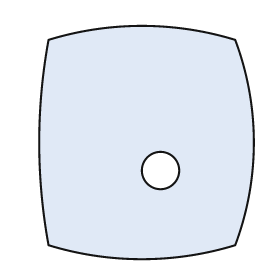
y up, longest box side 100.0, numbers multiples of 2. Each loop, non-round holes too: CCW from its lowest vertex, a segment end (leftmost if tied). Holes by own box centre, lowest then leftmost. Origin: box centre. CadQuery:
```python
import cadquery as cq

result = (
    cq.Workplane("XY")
    .moveTo(-42.0, -44.0)
    .threePointArc((-2.0, -50.0), (38.0, -44.0))
    .threePointArc((46.0, 0.0), (38.0, 44.0))
    .threePointArc((-2.0, 50.0), (-42.0, 44.0))
    .threePointArc((-46.0, 0.0), (-42.0, -44.0))
    .close()
    .moveTo(6.0, -12.0)
    .circle(8.0)
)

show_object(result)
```